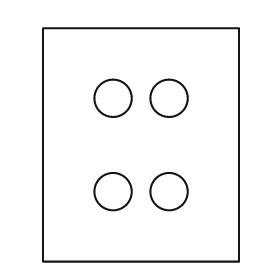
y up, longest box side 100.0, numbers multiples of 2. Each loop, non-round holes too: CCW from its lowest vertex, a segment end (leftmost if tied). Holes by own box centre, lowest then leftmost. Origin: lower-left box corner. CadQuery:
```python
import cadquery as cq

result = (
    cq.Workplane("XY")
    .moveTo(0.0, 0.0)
    .lineTo(84.0, 0.0)
    .lineTo(84.0, 100.0)
    .lineTo(0.0, 100.0)
    .close()
    .moveTo(30.0, 30.0)
    .circle(8.0)
    .moveTo(54.0, 30.0)
    .circle(8.0)
    .moveTo(30.0, 70.0)
    .circle(8.0)
    .moveTo(54.0, 70.0)
    .circle(8.0)
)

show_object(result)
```